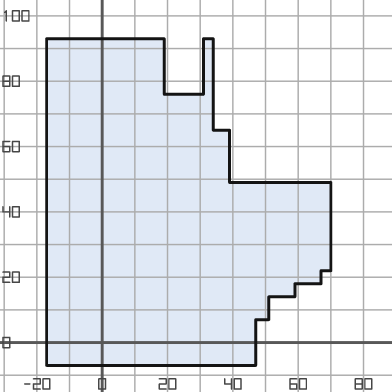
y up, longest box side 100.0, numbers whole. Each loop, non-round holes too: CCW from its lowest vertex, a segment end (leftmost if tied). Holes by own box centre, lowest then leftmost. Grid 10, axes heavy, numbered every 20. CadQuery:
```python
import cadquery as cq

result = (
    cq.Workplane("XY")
    .moveTo(-17.0, -7.0)
    .lineTo(47.0, -7.0)
    .lineTo(47.0, 7.0)
    .lineTo(51.0, 7.0)
    .lineTo(51.0, 14.0)
    .lineTo(59.0, 14.0)
    .lineTo(59.0, 18.0)
    .lineTo(67.0, 18.0)
    .lineTo(67.0, 22.0)
    .lineTo(70.0, 22.0)
    .lineTo(70.0, 49.0)
    .lineTo(39.0, 49.0)
    .lineTo(39.0, 65.0)
    .lineTo(34.0, 65.0)
    .lineTo(34.0, 93.0)
    .lineTo(31.0, 93.0)
    .lineTo(31.0, 76.0)
    .lineTo(19.0, 76.0)
    .lineTo(19.0, 93.0)
    .lineTo(-17.0, 93.0)
    .close()
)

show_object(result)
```